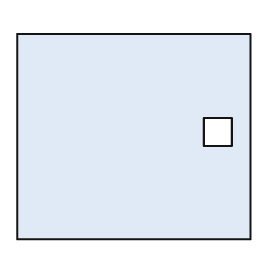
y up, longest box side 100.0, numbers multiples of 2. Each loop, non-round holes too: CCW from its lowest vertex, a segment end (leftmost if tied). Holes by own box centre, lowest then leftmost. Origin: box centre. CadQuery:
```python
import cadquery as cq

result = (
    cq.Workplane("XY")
    .moveTo(-50.0, -44.0)
    .lineTo(50.0, -44.0)
    .lineTo(50.0, 44.0)
    .lineTo(-50.0, 44.0)
    .close()
    .moveTo(30.0, -4.0)
    .lineTo(42.0, -4.0)
    .lineTo(42.0, 8.0)
    .lineTo(30.0, 8.0)
    .close()
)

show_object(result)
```